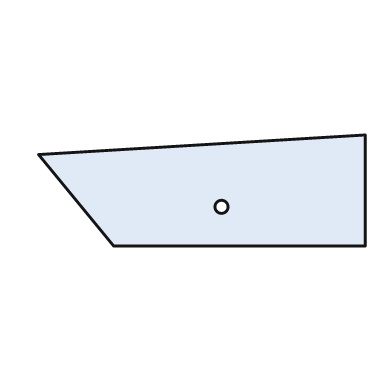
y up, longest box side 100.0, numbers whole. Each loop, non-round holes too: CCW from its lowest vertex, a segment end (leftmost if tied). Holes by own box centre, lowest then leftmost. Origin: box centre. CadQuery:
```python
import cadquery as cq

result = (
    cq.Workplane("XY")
    .moveTo(-27.0, -17.0)
    .lineTo(50.0, -17.0)
    .lineTo(50.0, 17.0)
    .lineTo(-50.0, 11.0)
    .close()
    .moveTo(6.0, -5.0)
    .circle(2.0)
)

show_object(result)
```